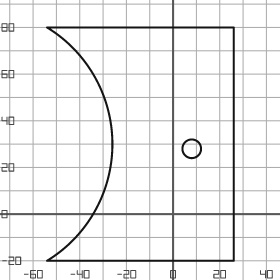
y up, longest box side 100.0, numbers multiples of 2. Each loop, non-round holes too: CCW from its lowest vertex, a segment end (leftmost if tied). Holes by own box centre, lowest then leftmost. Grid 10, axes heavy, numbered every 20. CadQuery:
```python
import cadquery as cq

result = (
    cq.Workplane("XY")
    .moveTo(-54.0, -20.0)
    .lineTo(26.0, -20.0)
    .lineTo(26.0, 80.0)
    .lineTo(-54.0, 80.0)
    .threePointArc((-26.0, 30.0), (-54.0, -20.0))
    .close()
    .moveTo(8.0, 28.0)
    .circle(4.0)
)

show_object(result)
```